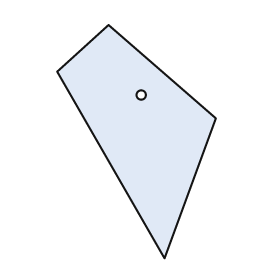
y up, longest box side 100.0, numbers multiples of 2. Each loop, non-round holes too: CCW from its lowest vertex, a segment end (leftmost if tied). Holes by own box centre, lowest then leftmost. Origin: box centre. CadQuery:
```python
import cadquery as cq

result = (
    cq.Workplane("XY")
    .moveTo(12.0, -50.0)
    .lineTo(34.0, 10.0)
    .lineTo(-12.0, 50.0)
    .lineTo(-34.0, 30.0)
    .close()
    .moveTo(2.0, 20.0)
    .circle(2.0)
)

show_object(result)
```